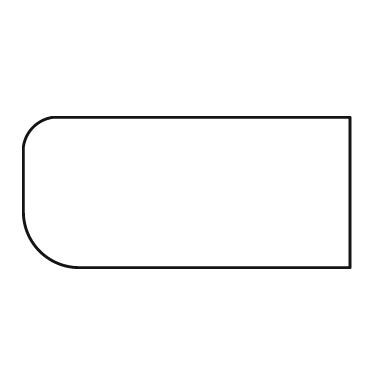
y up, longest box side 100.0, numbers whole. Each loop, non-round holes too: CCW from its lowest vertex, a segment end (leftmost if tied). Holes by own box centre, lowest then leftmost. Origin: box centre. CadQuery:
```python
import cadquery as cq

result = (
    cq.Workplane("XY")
    .moveTo(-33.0, -23.0)
    .lineTo(50.0, -23.0)
    .lineTo(50.0, 23.0)
    .lineTo(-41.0, 23.0)
    .threePointArc((-47.0, 20.0), (-50.0, 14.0))
    .lineTo(-50.0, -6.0)
    .threePointArc((-45.0, -18.0), (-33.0, -23.0))
    .close()
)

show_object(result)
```